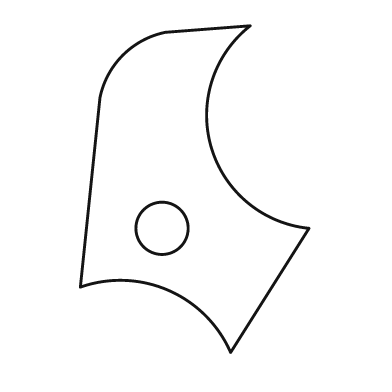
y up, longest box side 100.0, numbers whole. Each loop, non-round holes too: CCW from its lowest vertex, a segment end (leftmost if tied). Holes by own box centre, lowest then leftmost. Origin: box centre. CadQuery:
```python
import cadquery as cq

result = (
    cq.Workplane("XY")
    .moveTo(11.0, -50.0)
    .lineTo(35.0, -12.0)
    .threePointArc((5.0, 13.0), (17.0, 50.0))
    .lineTo(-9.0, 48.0)
    .threePointArc((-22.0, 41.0), (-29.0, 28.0))
    .lineTo(-35.0, -30.0)
    .threePointArc((-8.0, -31.0), (11.0, -50.0))
    .close()
    .moveTo(-10.0, -12.0)
    .circle(8.0)
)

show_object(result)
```